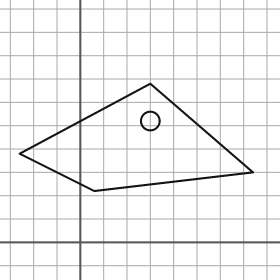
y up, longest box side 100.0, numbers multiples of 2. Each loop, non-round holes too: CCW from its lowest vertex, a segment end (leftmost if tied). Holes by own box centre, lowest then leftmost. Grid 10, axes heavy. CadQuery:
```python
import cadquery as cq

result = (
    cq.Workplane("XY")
    .moveTo(6.0, 22.0)
    .lineTo(74.0, 30.0)
    .lineTo(30.0, 68.0)
    .lineTo(-26.0, 38.0)
    .close()
    .moveTo(30.0, 52.0)
    .circle(4.0)
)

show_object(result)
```